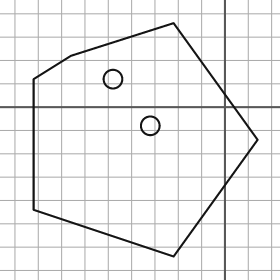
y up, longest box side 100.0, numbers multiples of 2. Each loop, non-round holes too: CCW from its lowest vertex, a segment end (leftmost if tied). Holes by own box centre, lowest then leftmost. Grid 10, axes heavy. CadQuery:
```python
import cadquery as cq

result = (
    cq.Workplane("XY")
    .moveTo(-22.0, -64.0)
    .lineTo(14.0, -14.0)
    .lineTo(-22.0, 36.0)
    .lineTo(-66.0, 22.0)
    .lineTo(-82.0, 12.0)
    .lineTo(-82.0, -44.0)
    .close()
    .moveTo(-32.0, -8.0)
    .circle(4.0)
    .moveTo(-48.0, 12.0)
    .circle(4.0)
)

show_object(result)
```